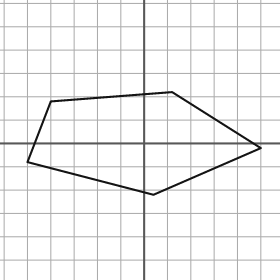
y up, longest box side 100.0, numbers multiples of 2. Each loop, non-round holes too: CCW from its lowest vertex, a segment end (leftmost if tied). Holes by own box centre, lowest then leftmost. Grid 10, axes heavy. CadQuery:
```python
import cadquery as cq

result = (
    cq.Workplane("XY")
    .moveTo(4.0, -22.0)
    .lineTo(50.0, -2.0)
    .lineTo(12.0, 22.0)
    .lineTo(-40.0, 18.0)
    .lineTo(-50.0, -8.0)
    .close()
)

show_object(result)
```